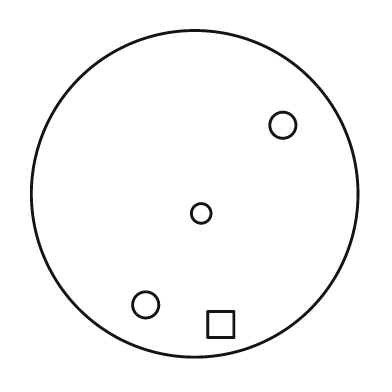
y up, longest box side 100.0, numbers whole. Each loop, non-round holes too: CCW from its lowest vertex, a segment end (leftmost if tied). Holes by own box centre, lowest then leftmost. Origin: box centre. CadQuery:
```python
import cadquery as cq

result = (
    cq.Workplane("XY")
    .moveTo(0.0, 0.0)
    .circle(50.0)
    .moveTo(4.0, -44.0)
    .lineTo(12.0, -44.0)
    .lineTo(12.0, -36.0)
    .lineTo(4.0, -36.0)
    .close()
    .moveTo(-15.0, -34.0)
    .circle(4.0)
    .moveTo(2.0, -6.0)
    .circle(3.0)
    .moveTo(27.0, 21.0)
    .circle(4.0)
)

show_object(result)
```